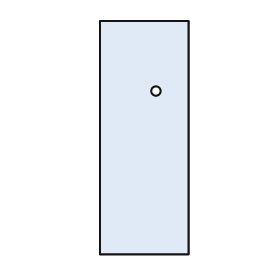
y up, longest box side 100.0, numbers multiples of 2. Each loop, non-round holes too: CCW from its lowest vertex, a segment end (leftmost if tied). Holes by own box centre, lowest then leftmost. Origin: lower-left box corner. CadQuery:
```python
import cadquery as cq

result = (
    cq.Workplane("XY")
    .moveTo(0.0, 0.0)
    .lineTo(38.0, 0.0)
    .lineTo(38.0, 100.0)
    .lineTo(0.0, 100.0)
    .close()
    .moveTo(24.0, 70.0)
    .circle(2.0)
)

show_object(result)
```